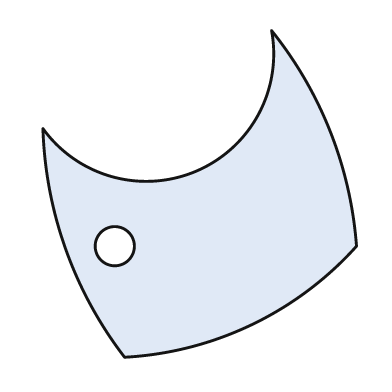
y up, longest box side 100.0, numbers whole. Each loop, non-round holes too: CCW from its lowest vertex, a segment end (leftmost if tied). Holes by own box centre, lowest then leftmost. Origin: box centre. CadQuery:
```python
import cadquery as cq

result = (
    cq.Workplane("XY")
    .moveTo(-23.0, -50.0)
    .threePointArc((16.0, -40.0), (48.0, -16.0))
    .threePointArc((40.0, 19.0), (22.0, 50.0))
    .threePointArc((-1.0, 7.0), (-48.0, 20.0))
    .threePointArc((-41.0, -17.0), (-23.0, -50.0))
    .close()
    .moveTo(-26.0, -16.0)
    .circle(6.0)
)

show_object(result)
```